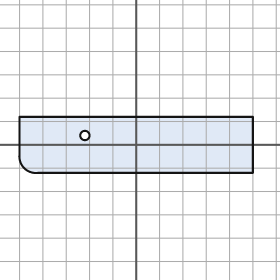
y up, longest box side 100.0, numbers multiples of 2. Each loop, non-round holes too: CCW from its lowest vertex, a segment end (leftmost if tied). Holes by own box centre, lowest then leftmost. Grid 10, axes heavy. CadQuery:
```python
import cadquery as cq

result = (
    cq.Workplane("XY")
    .moveTo(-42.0, -12.0)
    .lineTo(50.0, -12.0)
    .lineTo(50.0, 12.0)
    .lineTo(-50.0, 12.0)
    .lineTo(-50.0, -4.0)
    .threePointArc((-48.0, -10.0), (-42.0, -12.0))
    .close()
    .moveTo(-22.0, 4.0)
    .circle(2.0)
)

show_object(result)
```